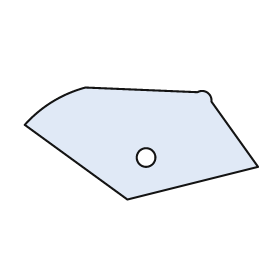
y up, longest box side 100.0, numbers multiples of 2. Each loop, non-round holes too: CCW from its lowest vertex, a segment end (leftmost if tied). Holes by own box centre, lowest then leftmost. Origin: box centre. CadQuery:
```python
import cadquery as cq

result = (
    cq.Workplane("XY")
    .moveTo(-6.0, -24.0)
    .lineTo(50.0, -10.0)
    .lineTo(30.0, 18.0)
    .threePointArc((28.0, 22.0), (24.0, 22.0))
    .lineTo(-24.0, 24.0)
    .threePointArc((-38.0, 18.0), (-50.0, 8.0))
    .close()
    .moveTo(2.0, -6.0)
    .circle(4.0)
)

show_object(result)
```